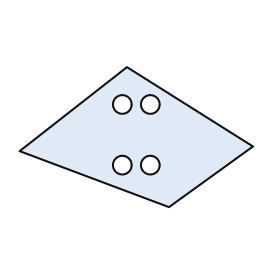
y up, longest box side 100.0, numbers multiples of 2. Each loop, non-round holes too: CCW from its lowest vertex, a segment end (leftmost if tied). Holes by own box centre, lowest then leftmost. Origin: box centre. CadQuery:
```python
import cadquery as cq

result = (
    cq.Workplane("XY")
    .moveTo(14.0, -30.0)
    .lineTo(50.0, -4.0)
    .lineTo(-4.0, 30.0)
    .lineTo(-50.0, -6.0)
    .close()
    .moveTo(-6.0, -12.0)
    .circle(4.0)
    .moveTo(6.0, -12.0)
    .circle(4.0)
    .moveTo(-6.0, 14.0)
    .circle(4.0)
    .moveTo(6.0, 14.0)
    .circle(4.0)
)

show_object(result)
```